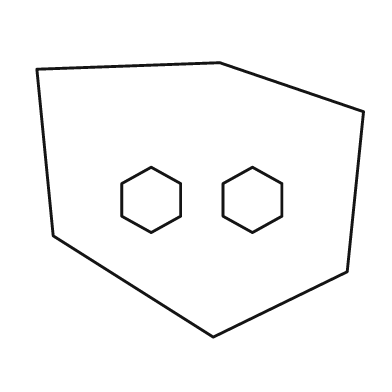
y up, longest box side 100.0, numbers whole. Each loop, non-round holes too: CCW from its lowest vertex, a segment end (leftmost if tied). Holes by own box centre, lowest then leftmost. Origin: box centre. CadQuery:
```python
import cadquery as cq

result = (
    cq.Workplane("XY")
    .moveTo(4.0, -42.0)
    .lineTo(45.0, -22.0)
    .lineTo(50.0, 27.0)
    .lineTo(6.0, 42.0)
    .lineTo(-50.0, 40.0)
    .lineTo(-45.0, -11.0)
    .close()
    .moveTo(-15.0, -10.0)
    .lineTo(-6.0, -5.0)
    .lineTo(-6.0, 5.0)
    .lineTo(-15.0, 10.0)
    .lineTo(-24.0, 5.0)
    .lineTo(-24.0, -5.0)
    .close()
    .moveTo(16.0, -10.0)
    .lineTo(25.0, -5.0)
    .lineTo(25.0, 5.0)
    .lineTo(16.0, 10.0)
    .lineTo(7.0, 5.0)
    .lineTo(7.0, -5.0)
    .close()
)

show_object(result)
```